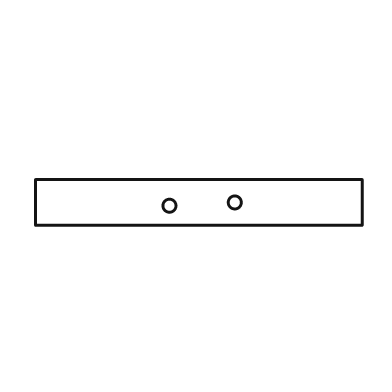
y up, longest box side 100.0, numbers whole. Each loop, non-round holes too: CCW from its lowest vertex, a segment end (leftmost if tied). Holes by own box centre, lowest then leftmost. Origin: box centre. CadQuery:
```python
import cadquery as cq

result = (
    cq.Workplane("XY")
    .moveTo(-50.0, -7.0)
    .lineTo(50.0, -7.0)
    .lineTo(50.0, 7.0)
    .lineTo(-50.0, 7.0)
    .close()
    .moveTo(-9.0, -1.0)
    .circle(2.0)
    .moveTo(11.0, 0.0)
    .circle(2.0)
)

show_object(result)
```